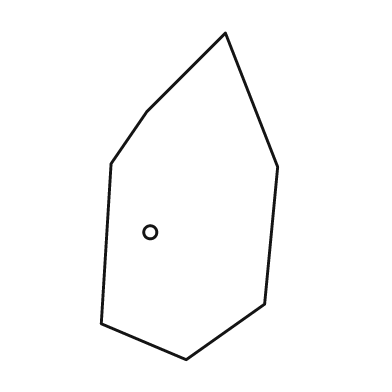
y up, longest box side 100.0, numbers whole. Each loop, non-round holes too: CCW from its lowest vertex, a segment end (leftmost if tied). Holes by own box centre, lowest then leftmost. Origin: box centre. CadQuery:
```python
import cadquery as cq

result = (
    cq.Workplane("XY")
    .moveTo(-1.0, -50.0)
    .lineTo(23.0, -33.0)
    .lineTo(27.0, 9.0)
    .lineTo(11.0, 50.0)
    .lineTo(-13.0, 26.0)
    .lineTo(-24.0, 10.0)
    .lineTo(-27.0, -39.0)
    .close()
    .moveTo(-12.0, -11.0)
    .circle(2.0)
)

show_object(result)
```